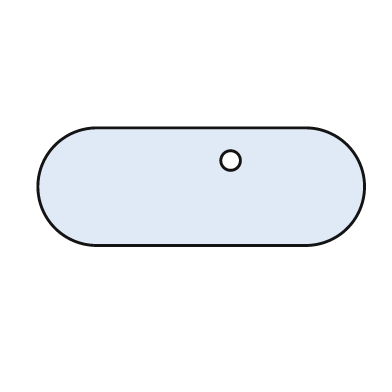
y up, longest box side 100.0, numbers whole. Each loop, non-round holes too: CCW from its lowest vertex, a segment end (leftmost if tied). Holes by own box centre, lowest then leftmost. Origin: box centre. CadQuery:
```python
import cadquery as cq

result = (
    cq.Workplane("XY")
    .moveTo(-32.0, -18.0)
    .lineTo(32.0, -18.0)
    .threePointArc((50.0, 0.0), (32.0, 18.0))
    .lineTo(-32.0, 18.0)
    .threePointArc((-50.0, 0.0), (-32.0, -18.0))
    .close()
    .moveTo(9.0, 8.0)
    .circle(3.0)
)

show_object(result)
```